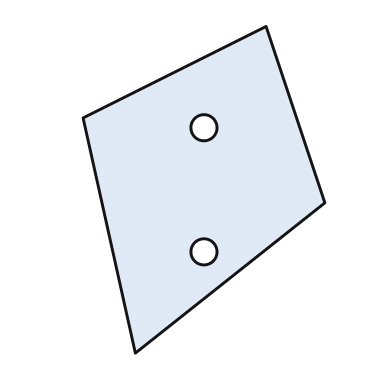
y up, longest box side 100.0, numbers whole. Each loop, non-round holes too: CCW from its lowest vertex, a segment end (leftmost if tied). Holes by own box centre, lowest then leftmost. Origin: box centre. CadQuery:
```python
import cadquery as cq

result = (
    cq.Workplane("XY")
    .moveTo(-21.0, -50.0)
    .lineTo(37.0, -4.0)
    .lineTo(19.0, 50.0)
    .lineTo(-37.0, 22.0)
    .close()
    .moveTo(0.0, -19.0)
    .circle(4.0)
    .moveTo(0.0, 19.0)
    .circle(4.0)
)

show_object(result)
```